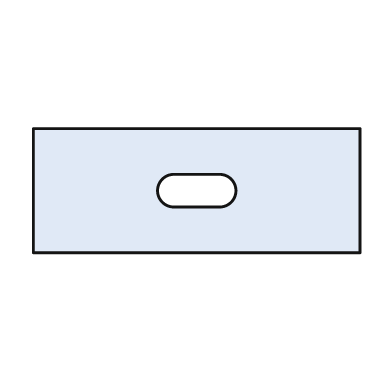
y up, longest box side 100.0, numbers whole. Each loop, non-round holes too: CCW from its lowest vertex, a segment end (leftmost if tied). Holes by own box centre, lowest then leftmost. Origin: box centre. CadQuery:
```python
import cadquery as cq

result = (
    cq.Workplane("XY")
    .moveTo(-50.0, -19.0)
    .lineTo(50.0, -19.0)
    .lineTo(50.0, 19.0)
    .lineTo(-50.0, 19.0)
    .close()
    .moveTo(-7.0, -5.0)
    .lineTo(7.0, -5.0)
    .threePointArc((12.0, 0.0), (7.0, 5.0))
    .lineTo(-7.0, 5.0)
    .threePointArc((-12.0, 0.0), (-7.0, -5.0))
    .close()
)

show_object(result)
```